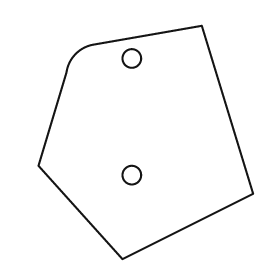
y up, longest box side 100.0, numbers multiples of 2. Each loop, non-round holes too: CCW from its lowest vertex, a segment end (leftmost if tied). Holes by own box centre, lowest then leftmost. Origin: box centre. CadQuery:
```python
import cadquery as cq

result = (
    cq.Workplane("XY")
    .moveTo(-10.0, -50.0)
    .lineTo(46.0, -22.0)
    .lineTo(24.0, 50.0)
    .lineTo(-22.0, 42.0)
    .threePointArc((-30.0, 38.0), (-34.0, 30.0))
    .lineTo(-46.0, -10.0)
    .close()
    .moveTo(-6.0, -14.0)
    .circle(4.0)
    .moveTo(-6.0, 36.0)
    .circle(4.0)
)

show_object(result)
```